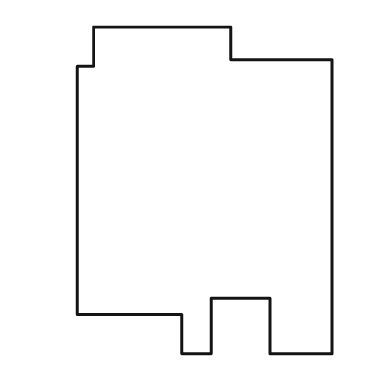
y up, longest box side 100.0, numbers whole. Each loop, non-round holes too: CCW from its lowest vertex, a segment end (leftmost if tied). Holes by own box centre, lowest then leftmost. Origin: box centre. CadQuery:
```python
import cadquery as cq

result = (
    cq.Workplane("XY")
    .moveTo(-7.0, -50.0)
    .lineTo(2.0, -50.0)
    .lineTo(2.0, -33.0)
    .lineTo(20.0, -33.0)
    .lineTo(20.0, -50.0)
    .lineTo(39.0, -50.0)
    .lineTo(39.0, 40.0)
    .lineTo(8.0, 40.0)
    .lineTo(8.0, 50.0)
    .lineTo(-34.0, 50.0)
    .lineTo(-34.0, 38.0)
    .lineTo(-39.0, 38.0)
    .lineTo(-39.0, -38.0)
    .lineTo(-7.0, -38.0)
    .close()
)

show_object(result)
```